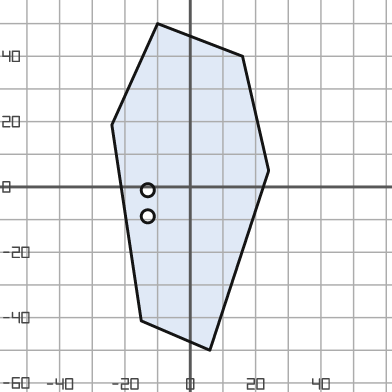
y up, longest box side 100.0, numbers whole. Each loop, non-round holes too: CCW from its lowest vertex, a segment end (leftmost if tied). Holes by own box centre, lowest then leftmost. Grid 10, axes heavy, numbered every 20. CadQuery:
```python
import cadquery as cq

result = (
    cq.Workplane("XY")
    .moveTo(6.0, -50.0)
    .lineTo(24.0, 5.0)
    .lineTo(16.0, 40.0)
    .lineTo(-10.0, 50.0)
    .lineTo(-24.0, 19.0)
    .lineTo(-15.0, -41.0)
    .close()
    .moveTo(-13.0, -9.0)
    .circle(2.0)
    .moveTo(-13.0, -1.0)
    .circle(2.0)
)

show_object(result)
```